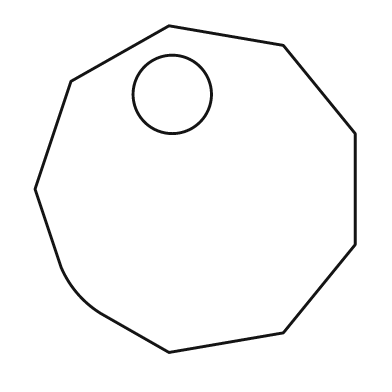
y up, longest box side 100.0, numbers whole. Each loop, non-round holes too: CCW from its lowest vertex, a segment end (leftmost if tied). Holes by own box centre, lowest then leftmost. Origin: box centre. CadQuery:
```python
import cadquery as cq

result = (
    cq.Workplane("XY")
    .moveTo(-8.0, -50.0)
    .lineTo(27.0, -44.0)
    .lineTo(49.0, -17.0)
    .lineTo(49.0, 17.0)
    .lineTo(27.0, 44.0)
    .lineTo(-8.0, 50.0)
    .lineTo(-38.0, 33.0)
    .lineTo(-49.0, 0.0)
    .lineTo(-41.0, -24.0)
    .threePointArc((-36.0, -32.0), (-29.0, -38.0))
    .close()
    .moveTo(-7.0, 29.0)
    .circle(12.0)
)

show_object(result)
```